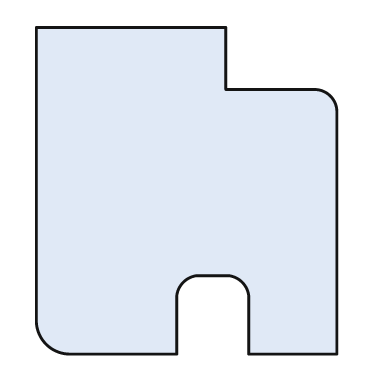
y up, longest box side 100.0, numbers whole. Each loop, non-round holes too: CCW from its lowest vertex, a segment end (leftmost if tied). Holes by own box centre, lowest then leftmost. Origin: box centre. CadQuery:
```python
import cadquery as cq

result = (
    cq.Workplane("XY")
    .moveTo(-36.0, -50.0)
    .lineTo(-3.0, -50.0)
    .lineTo(-3.0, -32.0)
    .threePointArc((-1.0, -28.0), (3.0, -26.0))
    .lineTo(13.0, -26.0)
    .threePointArc((17.0, -28.0), (19.0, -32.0))
    .lineTo(19.0, -50.0)
    .lineTo(46.0, -50.0)
    .lineTo(46.0, 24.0)
    .threePointArc((44.0, 29.0), (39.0, 31.0))
    .lineTo(12.0, 31.0)
    .lineTo(12.0, 50.0)
    .lineTo(-46.0, 50.0)
    .lineTo(-46.0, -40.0)
    .threePointArc((-43.0, -47.0), (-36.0, -50.0))
    .close()
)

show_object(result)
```